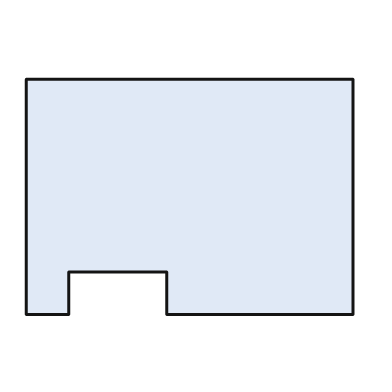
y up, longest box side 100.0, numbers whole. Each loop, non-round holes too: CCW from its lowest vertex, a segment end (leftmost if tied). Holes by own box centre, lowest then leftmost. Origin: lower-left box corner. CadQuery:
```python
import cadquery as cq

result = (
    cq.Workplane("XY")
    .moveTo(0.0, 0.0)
    .lineTo(13.0, 0.0)
    .lineTo(13.0, 13.0)
    .lineTo(43.0, 13.0)
    .lineTo(43.0, 0.0)
    .lineTo(100.0, 0.0)
    .lineTo(100.0, 72.0)
    .lineTo(0.0, 72.0)
    .close()
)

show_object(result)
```